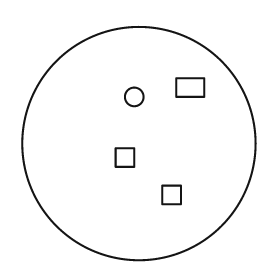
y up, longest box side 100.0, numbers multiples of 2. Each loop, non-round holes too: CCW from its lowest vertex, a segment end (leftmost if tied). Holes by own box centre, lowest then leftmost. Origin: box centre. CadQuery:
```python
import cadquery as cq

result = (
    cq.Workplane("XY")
    .moveTo(0.0, 0.0)
    .circle(50.0)
    .moveTo(10.0, -26.0)
    .lineTo(18.0, -26.0)
    .lineTo(18.0, -18.0)
    .lineTo(10.0, -18.0)
    .close()
    .moveTo(-10.0, -10.0)
    .lineTo(-2.0, -10.0)
    .lineTo(-2.0, -2.0)
    .lineTo(-10.0, -2.0)
    .close()
    .moveTo(-2.0, 20.0)
    .circle(4.0)
    .moveTo(16.0, 20.0)
    .lineTo(28.0, 20.0)
    .lineTo(28.0, 28.0)
    .lineTo(16.0, 28.0)
    .close()
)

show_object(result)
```